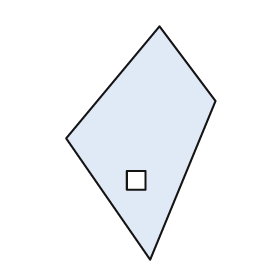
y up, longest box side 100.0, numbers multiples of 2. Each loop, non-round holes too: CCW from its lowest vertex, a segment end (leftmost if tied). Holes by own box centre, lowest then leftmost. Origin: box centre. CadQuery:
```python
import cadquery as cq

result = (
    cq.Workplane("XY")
    .moveTo(4.0, -50.0)
    .lineTo(32.0, 18.0)
    .lineTo(8.0, 50.0)
    .lineTo(-32.0, 2.0)
    .close()
    .moveTo(-6.0, -20.0)
    .lineTo(2.0, -20.0)
    .lineTo(2.0, -12.0)
    .lineTo(-6.0, -12.0)
    .close()
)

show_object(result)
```